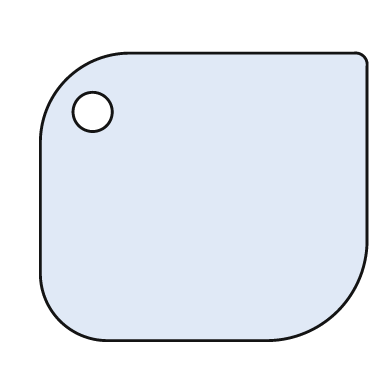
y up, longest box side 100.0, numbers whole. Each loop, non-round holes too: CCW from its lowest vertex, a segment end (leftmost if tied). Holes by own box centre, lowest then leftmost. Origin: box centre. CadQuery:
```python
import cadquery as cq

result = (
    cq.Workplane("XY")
    .moveTo(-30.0, -44.0)
    .lineTo(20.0, -44.0)
    .threePointArc((41.0, -35.0), (50.0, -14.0))
    .lineTo(50.0, 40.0)
    .threePointArc((49.0, 43.0), (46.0, 44.0))
    .lineTo(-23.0, 44.0)
    .threePointArc((-42.0, 36.0), (-50.0, 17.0))
    .lineTo(-50.0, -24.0)
    .threePointArc((-44.0, -38.0), (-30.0, -44.0))
    .close()
    .moveTo(-34.0, 26.0)
    .circle(6.0)
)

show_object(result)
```